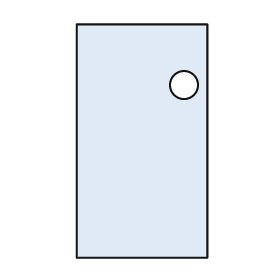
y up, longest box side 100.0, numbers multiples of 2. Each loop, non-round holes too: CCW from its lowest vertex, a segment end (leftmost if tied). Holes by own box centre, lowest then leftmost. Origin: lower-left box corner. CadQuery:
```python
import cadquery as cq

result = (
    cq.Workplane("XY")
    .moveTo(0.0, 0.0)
    .lineTo(56.0, 0.0)
    .lineTo(56.0, 100.0)
    .lineTo(0.0, 100.0)
    .close()
    .moveTo(46.0, 74.0)
    .circle(6.0)
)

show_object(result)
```